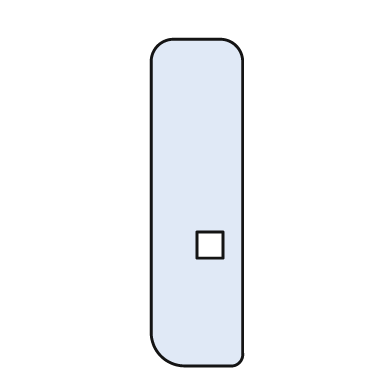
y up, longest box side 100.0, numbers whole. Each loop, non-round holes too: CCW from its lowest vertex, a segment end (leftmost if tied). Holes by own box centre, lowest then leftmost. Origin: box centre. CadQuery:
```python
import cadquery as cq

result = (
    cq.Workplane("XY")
    .moveTo(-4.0, -50.0)
    .lineTo(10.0, -50.0)
    .threePointArc((13.0, -49.0), (14.0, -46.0))
    .lineTo(14.0, 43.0)
    .threePointArc((12.0, 48.0), (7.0, 50.0))
    .lineTo(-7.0, 50.0)
    .threePointArc((-12.0, 48.0), (-14.0, 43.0))
    .lineTo(-14.0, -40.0)
    .threePointArc((-11.0, -47.0), (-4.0, -50.0))
    .close()
    .moveTo(0.0, -17.0)
    .lineTo(8.0, -17.0)
    .lineTo(8.0, -9.0)
    .lineTo(0.0, -9.0)
    .close()
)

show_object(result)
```